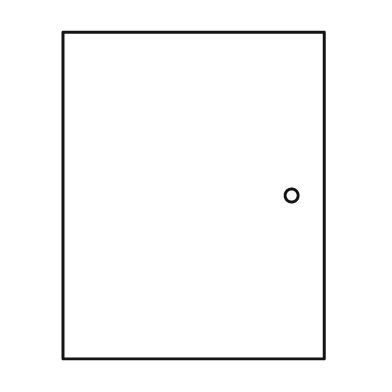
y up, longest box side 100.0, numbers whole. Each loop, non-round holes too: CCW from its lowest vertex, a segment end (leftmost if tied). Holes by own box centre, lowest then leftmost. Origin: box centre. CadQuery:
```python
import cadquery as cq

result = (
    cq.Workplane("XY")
    .moveTo(-40.0, -50.0)
    .lineTo(40.0, -50.0)
    .lineTo(40.0, 50.0)
    .lineTo(-40.0, 50.0)
    .close()
    .moveTo(30.0, 0.0)
    .circle(2.0)
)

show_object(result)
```